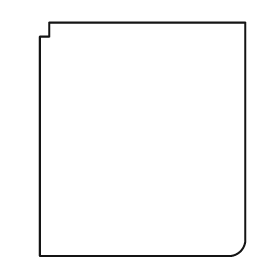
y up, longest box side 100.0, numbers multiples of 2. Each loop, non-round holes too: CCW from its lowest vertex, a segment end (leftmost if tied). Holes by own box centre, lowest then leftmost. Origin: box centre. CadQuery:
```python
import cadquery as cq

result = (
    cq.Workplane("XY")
    .moveTo(-44.0, -50.0)
    .lineTo(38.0, -50.0)
    .threePointArc((42.0, -48.0), (44.0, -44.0))
    .lineTo(44.0, 50.0)
    .lineTo(-40.0, 50.0)
    .lineTo(-40.0, 44.0)
    .lineTo(-44.0, 44.0)
    .close()
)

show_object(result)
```